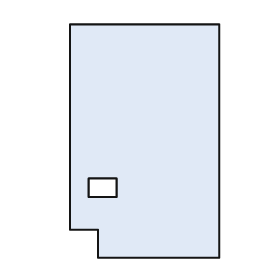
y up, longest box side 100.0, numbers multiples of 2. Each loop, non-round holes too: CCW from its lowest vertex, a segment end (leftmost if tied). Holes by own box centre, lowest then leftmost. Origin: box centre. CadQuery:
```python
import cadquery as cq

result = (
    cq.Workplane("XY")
    .moveTo(-20.0, -50.0)
    .lineTo(32.0, -50.0)
    .lineTo(32.0, 50.0)
    .lineTo(-32.0, 50.0)
    .lineTo(-32.0, -38.0)
    .lineTo(-20.0, -38.0)
    .close()
    .moveTo(-24.0, -24.0)
    .lineTo(-12.0, -24.0)
    .lineTo(-12.0, -16.0)
    .lineTo(-24.0, -16.0)
    .close()
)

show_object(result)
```